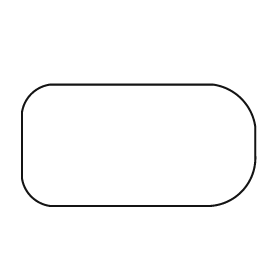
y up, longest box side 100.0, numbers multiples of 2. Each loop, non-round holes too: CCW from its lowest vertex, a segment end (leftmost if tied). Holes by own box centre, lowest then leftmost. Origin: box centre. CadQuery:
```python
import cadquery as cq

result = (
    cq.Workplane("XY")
    .moveTo(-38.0, -26.0)
    .lineTo(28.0, -26.0)
    .threePointArc((44.0, -20.0), (50.0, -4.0))
    .lineTo(50.0, 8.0)
    .threePointArc((44.0, 20.0), (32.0, 26.0))
    .lineTo(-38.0, 26.0)
    .threePointArc((-46.0, 22.0), (-50.0, 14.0))
    .lineTo(-50.0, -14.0)
    .threePointArc((-46.0, -22.0), (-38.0, -26.0))
    .close()
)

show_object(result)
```